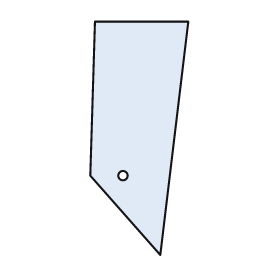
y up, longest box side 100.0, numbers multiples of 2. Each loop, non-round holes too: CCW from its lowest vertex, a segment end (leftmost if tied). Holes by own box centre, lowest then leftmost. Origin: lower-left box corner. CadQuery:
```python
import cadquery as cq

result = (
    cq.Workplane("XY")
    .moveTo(30.0, 0.0)
    .lineTo(42.0, 100.0)
    .lineTo(2.0, 100.0)
    .lineTo(0.0, 34.0)
    .close()
    .moveTo(14.0, 34.0)
    .circle(2.0)
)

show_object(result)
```